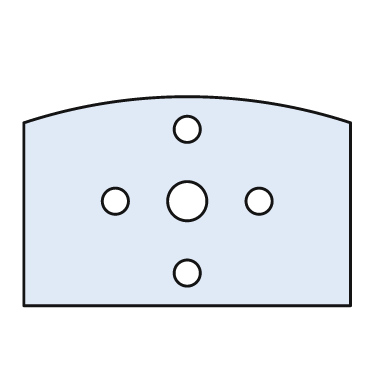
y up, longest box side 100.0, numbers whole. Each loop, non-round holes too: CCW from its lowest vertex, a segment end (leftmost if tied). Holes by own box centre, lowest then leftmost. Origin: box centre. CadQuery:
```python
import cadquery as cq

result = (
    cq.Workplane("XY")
    .moveTo(-50.0, -32.0)
    .lineTo(50.0, -32.0)
    .lineTo(50.0, 24.0)
    .threePointArc((0.0, 32.0), (-50.0, 24.0))
    .close()
    .moveTo(0.0, -22.0)
    .circle(4.0)
    .moveTo(-22.0, 0.0)
    .circle(4.0)
    .moveTo(0.0, 0.0)
    .circle(6.0)
    .moveTo(22.0, 0.0)
    .circle(4.0)
    .moveTo(0.0, 22.0)
    .circle(4.0)
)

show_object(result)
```